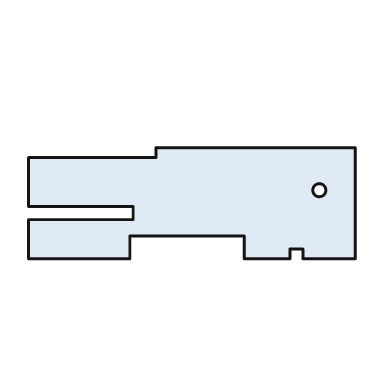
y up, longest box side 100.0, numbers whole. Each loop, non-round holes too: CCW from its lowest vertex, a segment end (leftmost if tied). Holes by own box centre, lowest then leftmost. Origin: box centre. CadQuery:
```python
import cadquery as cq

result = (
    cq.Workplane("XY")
    .moveTo(-50.0, -17.0)
    .lineTo(-19.0, -17.0)
    .lineTo(-19.0, -10.0)
    .lineTo(16.0, -10.0)
    .lineTo(16.0, -17.0)
    .lineTo(30.0, -17.0)
    .lineTo(30.0, -14.0)
    .lineTo(34.0, -14.0)
    .lineTo(34.0, -17.0)
    .lineTo(50.0, -17.0)
    .lineTo(50.0, 17.0)
    .lineTo(-11.0, 17.0)
    .lineTo(-11.0, 14.0)
    .lineTo(-50.0, 14.0)
    .lineTo(-50.0, -1.0)
    .lineTo(-18.0, -1.0)
    .lineTo(-18.0, -5.0)
    .lineTo(-50.0, -5.0)
    .close()
    .moveTo(39.0, 4.0)
    .circle(2.0)
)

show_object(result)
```